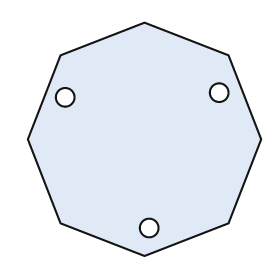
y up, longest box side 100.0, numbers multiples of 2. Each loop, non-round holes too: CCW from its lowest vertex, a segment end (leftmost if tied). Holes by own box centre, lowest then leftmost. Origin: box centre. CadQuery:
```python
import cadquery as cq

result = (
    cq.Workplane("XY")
    .moveTo(0.0, -50.0)
    .lineTo(36.0, -36.0)
    .lineTo(50.0, 0.0)
    .lineTo(36.0, 36.0)
    .lineTo(0.0, 50.0)
    .lineTo(-36.0, 36.0)
    .lineTo(-50.0, 0.0)
    .lineTo(-36.0, -36.0)
    .close()
    .moveTo(2.0, -38.0)
    .circle(4.0)
    .moveTo(-34.0, 18.0)
    .circle(4.0)
    .moveTo(32.0, 20.0)
    .circle(4.0)
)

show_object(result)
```